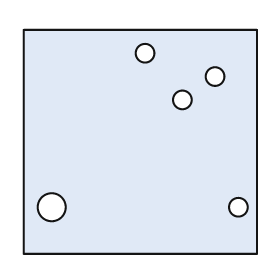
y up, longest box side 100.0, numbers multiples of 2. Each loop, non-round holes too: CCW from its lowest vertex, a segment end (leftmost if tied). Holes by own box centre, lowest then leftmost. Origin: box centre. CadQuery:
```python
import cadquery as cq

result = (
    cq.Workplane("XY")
    .moveTo(-50.0, -48.0)
    .lineTo(50.0, -48.0)
    .lineTo(50.0, 48.0)
    .lineTo(-50.0, 48.0)
    .close()
    .moveTo(-38.0, -28.0)
    .circle(6.0)
    .moveTo(42.0, -28.0)
    .circle(4.0)
    .moveTo(18.0, 18.0)
    .circle(4.0)
    .moveTo(32.0, 28.0)
    .circle(4.0)
    .moveTo(2.0, 38.0)
    .circle(4.0)
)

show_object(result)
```